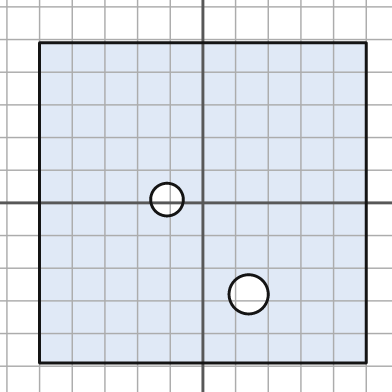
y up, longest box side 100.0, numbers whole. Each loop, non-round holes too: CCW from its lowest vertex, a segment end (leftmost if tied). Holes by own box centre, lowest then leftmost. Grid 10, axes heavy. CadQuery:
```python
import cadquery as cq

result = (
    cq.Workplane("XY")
    .moveTo(-50.0, -49.0)
    .lineTo(50.0, -49.0)
    .lineTo(50.0, 49.0)
    .lineTo(-50.0, 49.0)
    .close()
    .moveTo(14.0, -28.0)
    .circle(6.0)
    .moveTo(-11.0, 1.0)
    .circle(5.0)
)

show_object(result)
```